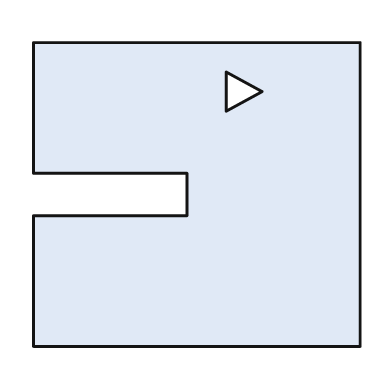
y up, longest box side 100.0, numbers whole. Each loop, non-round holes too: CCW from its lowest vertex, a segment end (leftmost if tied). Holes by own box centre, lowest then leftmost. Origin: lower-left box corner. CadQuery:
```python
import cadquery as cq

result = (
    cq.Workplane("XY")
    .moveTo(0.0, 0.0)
    .lineTo(100.0, 0.0)
    .lineTo(100.0, 93.0)
    .lineTo(0.0, 93.0)
    .lineTo(0.0, 53.0)
    .lineTo(47.0, 53.0)
    .lineTo(47.0, 40.0)
    .lineTo(0.0, 40.0)
    .close()
    .moveTo(59.0, 72.0)
    .lineTo(70.0, 78.0)
    .lineTo(59.0, 84.0)
    .close()
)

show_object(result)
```